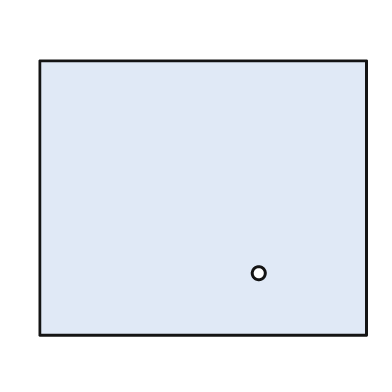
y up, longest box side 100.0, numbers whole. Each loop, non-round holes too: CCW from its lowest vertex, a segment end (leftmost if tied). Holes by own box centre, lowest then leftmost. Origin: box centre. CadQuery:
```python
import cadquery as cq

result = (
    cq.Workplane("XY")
    .moveTo(-50.0, -42.0)
    .lineTo(50.0, -42.0)
    .lineTo(50.0, 42.0)
    .lineTo(-50.0, 42.0)
    .close()
    .moveTo(17.0, -23.0)
    .circle(2.0)
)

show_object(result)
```